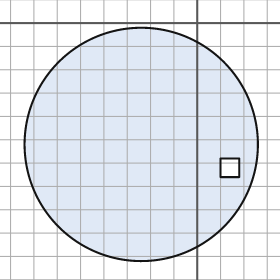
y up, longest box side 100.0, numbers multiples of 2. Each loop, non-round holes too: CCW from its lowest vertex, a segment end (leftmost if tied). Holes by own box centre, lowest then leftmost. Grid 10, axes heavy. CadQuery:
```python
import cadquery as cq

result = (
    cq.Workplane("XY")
    .moveTo(-24.0, -52.0)
    .circle(50.0)
    .moveTo(10.0, -66.0)
    .lineTo(18.0, -66.0)
    .lineTo(18.0, -58.0)
    .lineTo(10.0, -58.0)
    .close()
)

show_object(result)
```